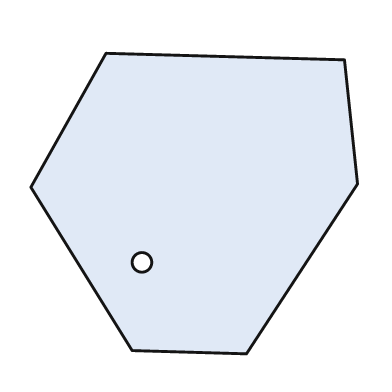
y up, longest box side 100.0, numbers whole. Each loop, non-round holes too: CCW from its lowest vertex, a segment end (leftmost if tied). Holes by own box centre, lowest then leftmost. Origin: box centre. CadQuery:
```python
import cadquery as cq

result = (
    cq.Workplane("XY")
    .moveTo(16.0, -46.0)
    .lineTo(50.0, 6.0)
    .lineTo(46.0, 44.0)
    .lineTo(-27.0, 46.0)
    .lineTo(-50.0, 5.0)
    .lineTo(-19.0, -45.0)
    .close()
    .moveTo(-16.0, -18.0)
    .circle(3.0)
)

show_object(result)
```